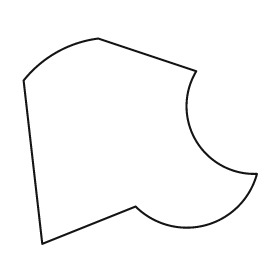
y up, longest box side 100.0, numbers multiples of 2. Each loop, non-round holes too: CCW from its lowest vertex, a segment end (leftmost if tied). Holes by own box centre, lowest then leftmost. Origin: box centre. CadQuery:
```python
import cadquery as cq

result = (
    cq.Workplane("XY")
    .moveTo(-42.0, -44.0)
    .lineTo(-2.0, -28.0)
    .threePointArc((28.0, -36.0), (50.0, -14.0))
    .threePointArc((24.0, 0.0), (24.0, 30.0))
    .lineTo(-18.0, 44.0)
    .threePointArc((-36.0, 38.0), (-50.0, 26.0))
    .close()
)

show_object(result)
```